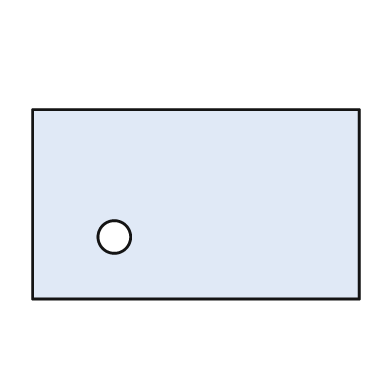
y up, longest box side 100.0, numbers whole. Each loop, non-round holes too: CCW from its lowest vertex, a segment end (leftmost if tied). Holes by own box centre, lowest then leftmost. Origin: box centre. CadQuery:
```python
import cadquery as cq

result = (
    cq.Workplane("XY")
    .moveTo(-50.0, -29.0)
    .lineTo(50.0, -29.0)
    .lineTo(50.0, 29.0)
    .lineTo(-50.0, 29.0)
    .close()
    .moveTo(-25.0, -10.0)
    .circle(5.0)
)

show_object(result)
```